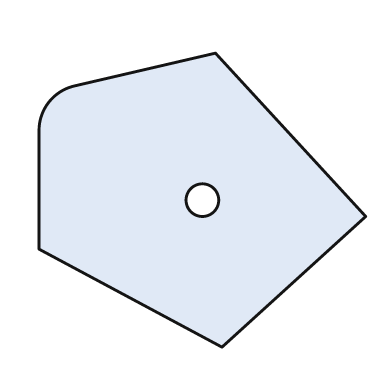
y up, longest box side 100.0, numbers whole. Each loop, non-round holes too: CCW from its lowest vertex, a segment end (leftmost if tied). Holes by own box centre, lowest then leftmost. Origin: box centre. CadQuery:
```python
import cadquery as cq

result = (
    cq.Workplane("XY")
    .moveTo(6.0, -45.0)
    .lineTo(50.0, -5.0)
    .lineTo(4.0, 45.0)
    .lineTo(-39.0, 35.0)
    .threePointArc((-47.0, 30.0), (-50.0, 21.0))
    .lineTo(-50.0, -15.0)
    .close()
    .moveTo(0.0, 0.0)
    .circle(5.0)
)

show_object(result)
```